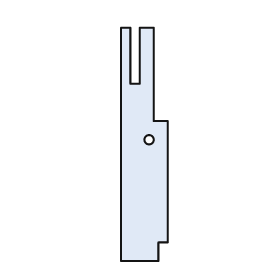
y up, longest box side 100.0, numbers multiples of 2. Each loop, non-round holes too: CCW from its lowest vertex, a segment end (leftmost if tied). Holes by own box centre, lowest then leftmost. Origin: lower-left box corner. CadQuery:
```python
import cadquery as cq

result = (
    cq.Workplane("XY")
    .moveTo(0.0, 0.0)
    .lineTo(16.0, 0.0)
    .lineTo(16.0, 8.0)
    .lineTo(20.0, 8.0)
    .lineTo(20.0, 60.0)
    .lineTo(14.0, 60.0)
    .lineTo(14.0, 100.0)
    .lineTo(8.0, 100.0)
    .lineTo(8.0, 76.0)
    .lineTo(4.0, 76.0)
    .lineTo(4.0, 100.0)
    .lineTo(0.0, 100.0)
    .close()
    .moveTo(12.0, 52.0)
    .circle(2.0)
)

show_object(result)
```